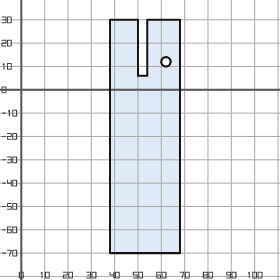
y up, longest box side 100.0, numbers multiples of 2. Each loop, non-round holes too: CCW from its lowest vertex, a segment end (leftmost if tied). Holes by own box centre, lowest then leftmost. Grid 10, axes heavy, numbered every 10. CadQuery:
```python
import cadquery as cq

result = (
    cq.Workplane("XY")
    .moveTo(38.0, -70.0)
    .lineTo(68.0, -70.0)
    .lineTo(68.0, 30.0)
    .lineTo(54.0, 30.0)
    .lineTo(54.0, 6.0)
    .lineTo(50.0, 6.0)
    .lineTo(50.0, 30.0)
    .lineTo(38.0, 30.0)
    .close()
    .moveTo(62.0, 12.0)
    .circle(2.0)
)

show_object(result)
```